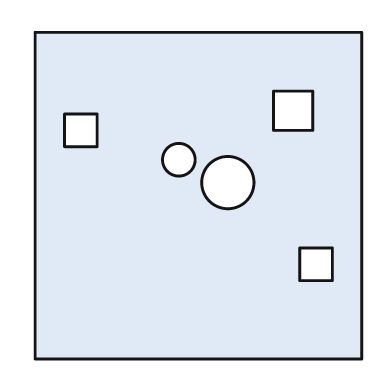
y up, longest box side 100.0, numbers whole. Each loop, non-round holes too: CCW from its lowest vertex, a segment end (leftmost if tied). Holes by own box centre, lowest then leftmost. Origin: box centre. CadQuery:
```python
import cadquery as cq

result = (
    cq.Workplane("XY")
    .moveTo(-50.0, -50.0)
    .lineTo(50.0, -50.0)
    .lineTo(50.0, 50.0)
    .lineTo(-50.0, 50.0)
    .close()
    .moveTo(31.0, -26.0)
    .lineTo(41.0, -26.0)
    .lineTo(41.0, -16.0)
    .lineTo(31.0, -16.0)
    .close()
    .moveTo(9.0, 4.0)
    .circle(8.0)
    .moveTo(-6.0, 11.0)
    .circle(5.0)
    .moveTo(-41.0, 15.0)
    .lineTo(-31.0, 15.0)
    .lineTo(-31.0, 25.0)
    .lineTo(-41.0, 25.0)
    .close()
    .moveTo(23.0, 20.0)
    .lineTo(35.0, 20.0)
    .lineTo(35.0, 32.0)
    .lineTo(23.0, 32.0)
    .close()
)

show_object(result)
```